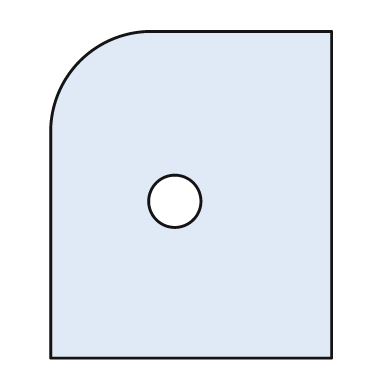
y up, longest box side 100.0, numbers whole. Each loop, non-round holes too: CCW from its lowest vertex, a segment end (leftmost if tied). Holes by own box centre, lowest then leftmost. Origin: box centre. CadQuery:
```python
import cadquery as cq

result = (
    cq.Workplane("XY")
    .moveTo(-43.0, -50.0)
    .lineTo(43.0, -50.0)
    .lineTo(43.0, 50.0)
    .lineTo(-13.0, 50.0)
    .threePointArc((-34.0, 41.0), (-43.0, 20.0))
    .close()
    .moveTo(-5.0, -2.0)
    .circle(8.0)
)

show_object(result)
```